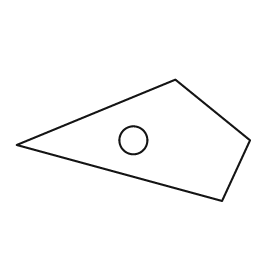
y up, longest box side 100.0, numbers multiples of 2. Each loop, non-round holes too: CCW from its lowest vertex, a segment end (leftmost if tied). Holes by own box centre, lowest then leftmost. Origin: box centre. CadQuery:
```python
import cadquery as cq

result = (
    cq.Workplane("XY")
    .moveTo(38.0, -26.0)
    .lineTo(50.0, 0.0)
    .lineTo(18.0, 26.0)
    .lineTo(-50.0, -2.0)
    .close()
    .moveTo(0.0, 0.0)
    .circle(6.0)
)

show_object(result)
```